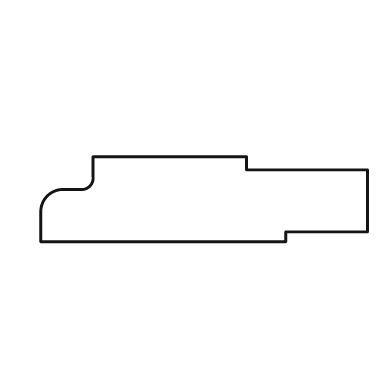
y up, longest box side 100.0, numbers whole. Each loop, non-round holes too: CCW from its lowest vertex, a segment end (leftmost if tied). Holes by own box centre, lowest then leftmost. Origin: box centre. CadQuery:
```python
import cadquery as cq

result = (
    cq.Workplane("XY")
    .moveTo(-50.0, -13.0)
    .lineTo(25.0, -13.0)
    .lineTo(25.0, -10.0)
    .lineTo(50.0, -10.0)
    .lineTo(50.0, 9.0)
    .lineTo(13.0, 9.0)
    .lineTo(13.0, 13.0)
    .lineTo(-34.0, 13.0)
    .lineTo(-34.0, 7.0)
    .threePointArc((-35.0, 4.0), (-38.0, 3.0))
    .lineTo(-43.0, 3.0)
    .threePointArc((-48.0, 1.0), (-50.0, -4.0))
    .close()
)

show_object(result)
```